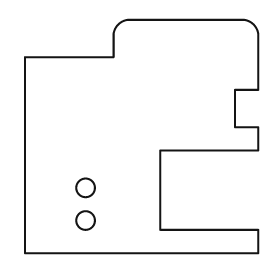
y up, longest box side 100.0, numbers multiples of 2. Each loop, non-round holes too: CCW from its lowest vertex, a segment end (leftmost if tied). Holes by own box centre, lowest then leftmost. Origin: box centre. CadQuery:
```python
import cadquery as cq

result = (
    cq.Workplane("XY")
    .moveTo(-50.0, -50.0)
    .lineTo(50.0, -50.0)
    .lineTo(50.0, -40.0)
    .lineTo(8.0, -40.0)
    .lineTo(8.0, -6.0)
    .lineTo(50.0, -6.0)
    .lineTo(50.0, 4.0)
    .lineTo(40.0, 4.0)
    .lineTo(40.0, 20.0)
    .lineTo(50.0, 20.0)
    .lineTo(50.0, 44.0)
    .threePointArc((48.0, 48.0), (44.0, 50.0))
    .lineTo(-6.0, 50.0)
    .threePointArc((-10.0, 48.0), (-12.0, 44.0))
    .lineTo(-12.0, 34.0)
    .lineTo(-50.0, 34.0)
    .close()
    .moveTo(-24.0, -36.0)
    .circle(4.0)
    .moveTo(-24.0, -22.0)
    .circle(4.0)
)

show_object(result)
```